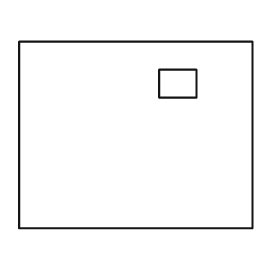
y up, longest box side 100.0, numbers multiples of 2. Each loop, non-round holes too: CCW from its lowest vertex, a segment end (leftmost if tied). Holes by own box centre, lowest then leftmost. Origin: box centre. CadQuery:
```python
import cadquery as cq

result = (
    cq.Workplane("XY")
    .moveTo(-50.0, -40.0)
    .lineTo(50.0, -40.0)
    .lineTo(50.0, 40.0)
    .lineTo(-50.0, 40.0)
    .close()
    .moveTo(10.0, 16.0)
    .lineTo(26.0, 16.0)
    .lineTo(26.0, 28.0)
    .lineTo(10.0, 28.0)
    .close()
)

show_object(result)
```